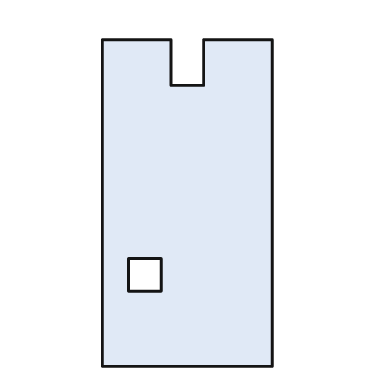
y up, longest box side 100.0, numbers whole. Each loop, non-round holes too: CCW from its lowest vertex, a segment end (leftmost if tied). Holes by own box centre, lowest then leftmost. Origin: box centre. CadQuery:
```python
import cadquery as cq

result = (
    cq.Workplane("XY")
    .moveTo(-26.0, -50.0)
    .lineTo(26.0, -50.0)
    .lineTo(26.0, 50.0)
    .lineTo(5.0, 50.0)
    .lineTo(5.0, 36.0)
    .lineTo(-5.0, 36.0)
    .lineTo(-5.0, 50.0)
    .lineTo(-26.0, 50.0)
    .close()
    .moveTo(-18.0, -27.0)
    .lineTo(-8.0, -27.0)
    .lineTo(-8.0, -17.0)
    .lineTo(-18.0, -17.0)
    .close()
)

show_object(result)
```